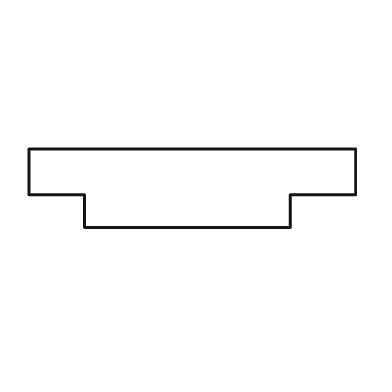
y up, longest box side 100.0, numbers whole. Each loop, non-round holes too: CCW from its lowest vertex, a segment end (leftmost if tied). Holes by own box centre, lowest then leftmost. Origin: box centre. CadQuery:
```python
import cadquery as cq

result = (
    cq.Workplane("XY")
    .moveTo(-33.0, -12.0)
    .lineTo(30.0, -12.0)
    .lineTo(30.0, -2.0)
    .lineTo(50.0, -2.0)
    .lineTo(50.0, 12.0)
    .lineTo(-50.0, 12.0)
    .lineTo(-50.0, -2.0)
    .lineTo(-33.0, -2.0)
    .close()
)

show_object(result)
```